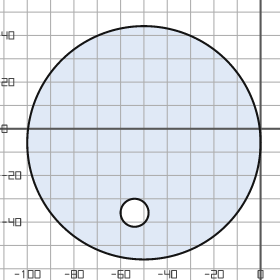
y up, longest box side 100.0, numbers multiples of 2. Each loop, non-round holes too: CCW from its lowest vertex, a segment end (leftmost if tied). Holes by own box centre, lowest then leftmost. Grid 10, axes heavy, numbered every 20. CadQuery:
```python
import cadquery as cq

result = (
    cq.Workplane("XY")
    .moveTo(-50.0, -6.0)
    .circle(50.0)
    .moveTo(-54.0, -36.0)
    .circle(6.0)
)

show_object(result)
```